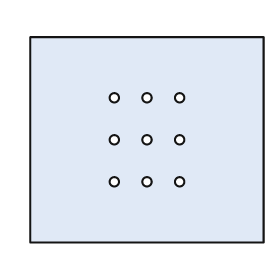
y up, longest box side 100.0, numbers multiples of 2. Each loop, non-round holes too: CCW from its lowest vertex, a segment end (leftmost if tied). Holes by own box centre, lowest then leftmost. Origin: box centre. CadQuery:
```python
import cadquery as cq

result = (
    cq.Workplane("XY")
    .moveTo(-50.0, -44.0)
    .lineTo(50.0, -44.0)
    .lineTo(50.0, 44.0)
    .lineTo(-50.0, 44.0)
    .close()
    .moveTo(-14.0, -18.0)
    .circle(2.0)
    .moveTo(0.0, -18.0)
    .circle(2.0)
    .moveTo(14.0, -18.0)
    .circle(2.0)
    .moveTo(-14.0, 0.0)
    .circle(2.0)
    .moveTo(0.0, 0.0)
    .circle(2.0)
    .moveTo(14.0, 0.0)
    .circle(2.0)
    .moveTo(-14.0, 18.0)
    .circle(2.0)
    .moveTo(0.0, 18.0)
    .circle(2.0)
    .moveTo(14.0, 18.0)
    .circle(2.0)
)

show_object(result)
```